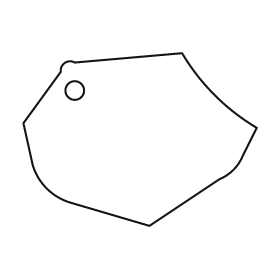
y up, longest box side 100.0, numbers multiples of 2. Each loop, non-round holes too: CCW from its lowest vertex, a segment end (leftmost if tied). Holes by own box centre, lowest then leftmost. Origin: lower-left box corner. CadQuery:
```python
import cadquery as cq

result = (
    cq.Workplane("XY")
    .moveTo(54.0, 0.0)
    .lineTo(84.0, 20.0)
    .threePointArc((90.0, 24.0), (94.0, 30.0))
    .lineTo(100.0, 42.0)
    .threePointArc((82.0, 56.0), (68.0, 74.0))
    .lineTo(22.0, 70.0)
    .threePointArc((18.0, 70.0), (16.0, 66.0))
    .lineTo(0.0, 44.0)
    .lineTo(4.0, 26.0)
    .threePointArc((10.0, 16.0), (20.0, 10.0))
    .close()
    .moveTo(22.0, 58.0)
    .circle(4.0)
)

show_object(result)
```